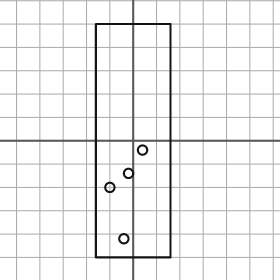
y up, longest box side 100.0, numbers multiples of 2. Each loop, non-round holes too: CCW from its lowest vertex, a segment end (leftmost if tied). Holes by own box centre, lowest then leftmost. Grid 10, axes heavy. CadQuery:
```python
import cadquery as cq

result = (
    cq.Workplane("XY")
    .moveTo(-16.0, -50.0)
    .lineTo(16.0, -50.0)
    .lineTo(16.0, 50.0)
    .lineTo(-16.0, 50.0)
    .close()
    .moveTo(-4.0, -42.0)
    .circle(2.0)
    .moveTo(-10.0, -20.0)
    .circle(2.0)
    .moveTo(-2.0, -14.0)
    .circle(2.0)
    .moveTo(4.0, -4.0)
    .circle(2.0)
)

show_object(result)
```